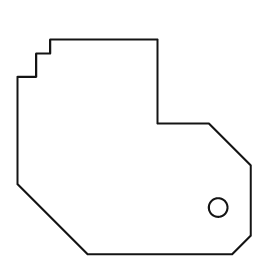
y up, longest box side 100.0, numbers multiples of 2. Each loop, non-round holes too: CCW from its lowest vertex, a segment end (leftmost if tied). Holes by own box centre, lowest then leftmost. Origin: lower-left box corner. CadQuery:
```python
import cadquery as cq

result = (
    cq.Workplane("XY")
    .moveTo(30.0, 0.0)
    .lineTo(92.0, 0.0)
    .lineTo(100.0, 8.0)
    .lineTo(100.0, 38.0)
    .lineTo(82.0, 56.0)
    .lineTo(60.0, 56.0)
    .lineTo(60.0, 92.0)
    .lineTo(14.0, 92.0)
    .lineTo(14.0, 86.0)
    .lineTo(8.0, 86.0)
    .lineTo(8.0, 76.0)
    .lineTo(0.0, 76.0)
    .lineTo(0.0, 30.0)
    .close()
    .moveTo(86.0, 20.0)
    .circle(4.0)
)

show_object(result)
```